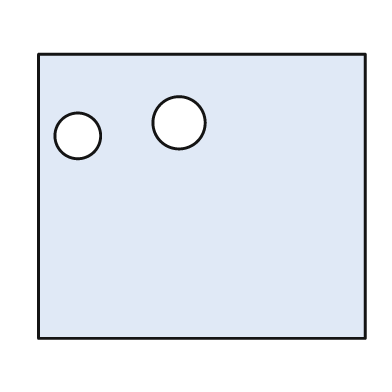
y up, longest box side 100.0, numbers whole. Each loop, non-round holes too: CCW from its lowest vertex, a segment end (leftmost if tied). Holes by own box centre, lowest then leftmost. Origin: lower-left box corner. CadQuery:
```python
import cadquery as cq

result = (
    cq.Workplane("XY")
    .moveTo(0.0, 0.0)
    .lineTo(100.0, 0.0)
    .lineTo(100.0, 87.0)
    .lineTo(0.0, 87.0)
    .close()
    .moveTo(12.0, 62.0)
    .circle(7.0)
    .moveTo(43.0, 66.0)
    .circle(8.0)
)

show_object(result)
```